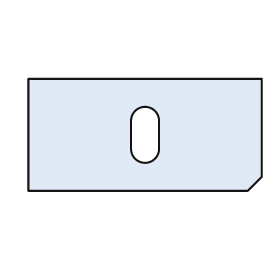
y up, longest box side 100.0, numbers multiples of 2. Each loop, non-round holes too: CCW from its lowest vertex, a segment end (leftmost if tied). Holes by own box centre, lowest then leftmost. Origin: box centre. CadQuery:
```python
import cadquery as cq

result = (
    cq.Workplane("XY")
    .moveTo(-50.0, -24.0)
    .lineTo(44.0, -24.0)
    .lineTo(50.0, -18.0)
    .lineTo(50.0, 24.0)
    .lineTo(-50.0, 24.0)
    .close()
    .moveTo(-6.0, -6.0)
    .threePointArc((0.0, -12.0), (6.0, -6.0))
    .lineTo(6.0, 6.0)
    .threePointArc((0.0, 12.0), (-6.0, 6.0))
    .close()
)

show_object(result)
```